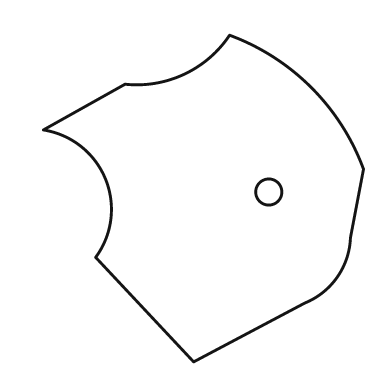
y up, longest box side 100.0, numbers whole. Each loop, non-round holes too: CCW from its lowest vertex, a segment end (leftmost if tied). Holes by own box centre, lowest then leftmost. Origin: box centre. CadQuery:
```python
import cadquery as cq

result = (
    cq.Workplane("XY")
    .moveTo(-3.0, -50.0)
    .lineTo(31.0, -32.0)
    .threePointArc((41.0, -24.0), (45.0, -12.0))
    .lineTo(49.0, 9.0)
    .threePointArc((33.0, 34.0), (8.0, 50.0))
    .threePointArc((-6.0, 38.0), (-24.0, 35.0))
    .lineTo(-49.0, 21.0)
    .threePointArc((-30.0, 6.0), (-33.0, -18.0))
    .close()
    .moveTo(20.0, 2.0)
    .circle(4.0)
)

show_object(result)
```